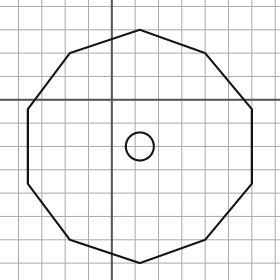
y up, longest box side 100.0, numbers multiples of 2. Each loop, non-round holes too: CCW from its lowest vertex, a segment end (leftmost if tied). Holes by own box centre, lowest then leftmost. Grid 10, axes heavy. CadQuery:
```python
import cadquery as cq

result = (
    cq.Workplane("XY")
    .moveTo(12.0, -70.0)
    .lineTo(40.0, -60.0)
    .lineTo(60.0, -36.0)
    .lineTo(60.0, -4.0)
    .lineTo(40.0, 20.0)
    .lineTo(12.0, 30.0)
    .lineTo(-18.0, 20.0)
    .lineTo(-36.0, -4.0)
    .lineTo(-36.0, -36.0)
    .lineTo(-18.0, -60.0)
    .close()
    .moveTo(12.0, -20.0)
    .circle(6.0)
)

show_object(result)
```